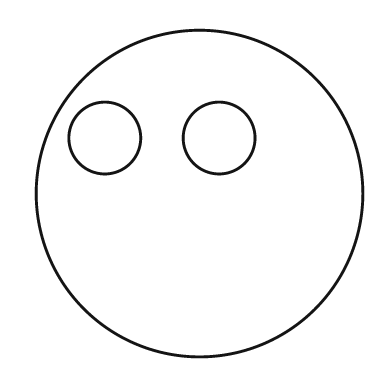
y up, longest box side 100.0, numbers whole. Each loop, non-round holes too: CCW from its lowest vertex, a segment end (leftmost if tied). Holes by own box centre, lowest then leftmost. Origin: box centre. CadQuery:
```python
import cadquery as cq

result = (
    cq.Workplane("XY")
    .moveTo(0.0, 0.0)
    .circle(50.0)
    .moveTo(-29.0, 17.0)
    .circle(11.0)
    .moveTo(6.0, 17.0)
    .circle(11.0)
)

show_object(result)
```